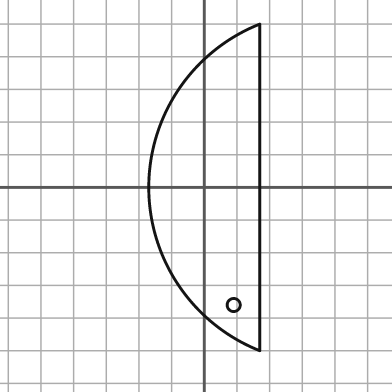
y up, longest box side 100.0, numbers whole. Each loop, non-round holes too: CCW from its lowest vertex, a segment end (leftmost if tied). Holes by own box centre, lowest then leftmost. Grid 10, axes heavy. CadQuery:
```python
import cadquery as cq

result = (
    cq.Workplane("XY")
    .moveTo(17.0, -50.0)
    .lineTo(17.0, 50.0)
    .threePointArc((-17.0, 0.0), (17.0, -50.0))
    .close()
    .moveTo(9.0, -36.0)
    .circle(2.0)
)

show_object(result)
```